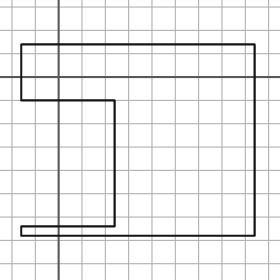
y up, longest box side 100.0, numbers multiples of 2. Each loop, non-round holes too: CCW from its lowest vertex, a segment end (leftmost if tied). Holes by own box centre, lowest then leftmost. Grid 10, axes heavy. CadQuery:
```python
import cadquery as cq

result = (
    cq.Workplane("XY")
    .moveTo(-16.0, -68.0)
    .lineTo(84.0, -68.0)
    .lineTo(84.0, 14.0)
    .lineTo(-16.0, 14.0)
    .lineTo(-16.0, -10.0)
    .lineTo(24.0, -10.0)
    .lineTo(24.0, -64.0)
    .lineTo(-16.0, -64.0)
    .close()
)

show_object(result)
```